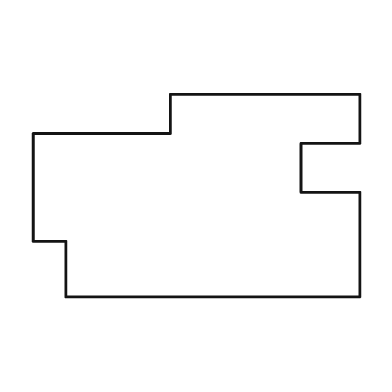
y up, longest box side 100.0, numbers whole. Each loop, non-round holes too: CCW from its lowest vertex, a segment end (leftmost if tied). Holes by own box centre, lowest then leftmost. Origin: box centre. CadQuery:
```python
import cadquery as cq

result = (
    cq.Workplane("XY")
    .moveTo(-40.0, -31.0)
    .lineTo(50.0, -31.0)
    .lineTo(50.0, 1.0)
    .lineTo(32.0, 1.0)
    .lineTo(32.0, 16.0)
    .lineTo(50.0, 16.0)
    .lineTo(50.0, 31.0)
    .lineTo(-8.0, 31.0)
    .lineTo(-8.0, 19.0)
    .lineTo(-50.0, 19.0)
    .lineTo(-50.0, -14.0)
    .lineTo(-40.0, -14.0)
    .close()
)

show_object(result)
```